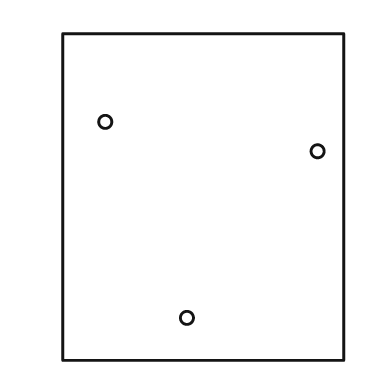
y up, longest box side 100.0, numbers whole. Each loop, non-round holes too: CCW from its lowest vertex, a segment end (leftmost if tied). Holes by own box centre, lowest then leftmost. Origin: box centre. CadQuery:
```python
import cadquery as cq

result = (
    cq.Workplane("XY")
    .moveTo(-43.0, -50.0)
    .lineTo(43.0, -50.0)
    .lineTo(43.0, 50.0)
    .lineTo(-43.0, 50.0)
    .close()
    .moveTo(-5.0, -37.0)
    .circle(2.0)
    .moveTo(35.0, 14.0)
    .circle(2.0)
    .moveTo(-30.0, 23.0)
    .circle(2.0)
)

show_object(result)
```